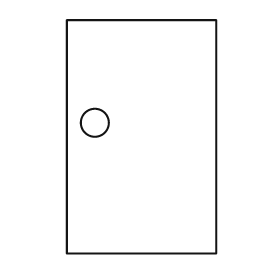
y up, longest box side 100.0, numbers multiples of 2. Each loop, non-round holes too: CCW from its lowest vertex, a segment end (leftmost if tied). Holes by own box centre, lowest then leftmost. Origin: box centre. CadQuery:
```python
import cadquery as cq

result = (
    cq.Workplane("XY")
    .moveTo(-32.0, -50.0)
    .lineTo(32.0, -50.0)
    .lineTo(32.0, 50.0)
    .lineTo(-32.0, 50.0)
    .close()
    .moveTo(-20.0, 6.0)
    .circle(6.0)
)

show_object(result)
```